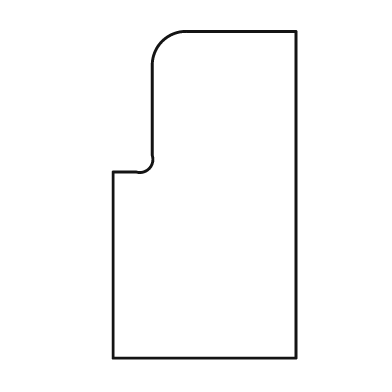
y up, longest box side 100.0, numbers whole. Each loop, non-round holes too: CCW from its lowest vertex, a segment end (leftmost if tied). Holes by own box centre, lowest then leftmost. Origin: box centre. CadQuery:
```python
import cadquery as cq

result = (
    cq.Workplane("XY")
    .moveTo(-28.0, -50.0)
    .lineTo(28.0, -50.0)
    .lineTo(28.0, 50.0)
    .lineTo(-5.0, 50.0)
    .threePointArc((-13.0, 47.0), (-16.0, 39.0))
    .lineTo(-16.0, 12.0)
    .threePointArc((-17.0, 8.0), (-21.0, 7.0))
    .lineTo(-28.0, 7.0)
    .close()
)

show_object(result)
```